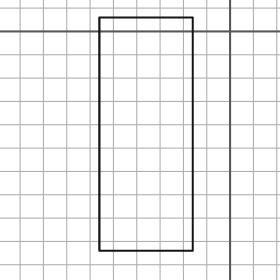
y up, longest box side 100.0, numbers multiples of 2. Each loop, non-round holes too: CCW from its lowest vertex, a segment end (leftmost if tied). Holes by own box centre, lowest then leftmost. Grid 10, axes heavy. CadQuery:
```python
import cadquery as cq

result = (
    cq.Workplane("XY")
    .moveTo(-56.0, -94.0)
    .lineTo(-16.0, -94.0)
    .lineTo(-16.0, 6.0)
    .lineTo(-56.0, 6.0)
    .close()
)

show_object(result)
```